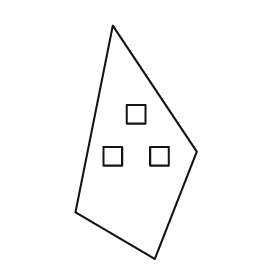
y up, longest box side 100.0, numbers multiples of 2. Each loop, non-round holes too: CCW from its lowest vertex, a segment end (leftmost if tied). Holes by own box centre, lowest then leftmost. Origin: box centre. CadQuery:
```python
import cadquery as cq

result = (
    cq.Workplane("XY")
    .moveTo(8.0, -50.0)
    .lineTo(26.0, -4.0)
    .lineTo(-10.0, 50.0)
    .lineTo(-26.0, -30.0)
    .close()
    .moveTo(-14.0, -10.0)
    .lineTo(-6.0, -10.0)
    .lineTo(-6.0, -2.0)
    .lineTo(-14.0, -2.0)
    .close()
    .moveTo(6.0, -10.0)
    .lineTo(14.0, -10.0)
    .lineTo(14.0, -2.0)
    .lineTo(6.0, -2.0)
    .close()
    .moveTo(-4.0, 8.0)
    .lineTo(4.0, 8.0)
    .lineTo(4.0, 16.0)
    .lineTo(-4.0, 16.0)
    .close()
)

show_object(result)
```